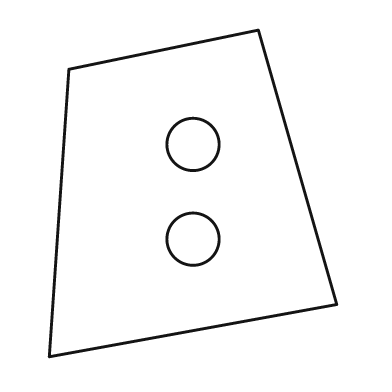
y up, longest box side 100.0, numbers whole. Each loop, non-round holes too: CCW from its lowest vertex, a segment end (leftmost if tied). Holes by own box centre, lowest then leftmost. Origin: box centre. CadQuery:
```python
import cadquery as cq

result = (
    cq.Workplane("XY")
    .moveTo(-44.0, -50.0)
    .lineTo(44.0, -34.0)
    .lineTo(20.0, 50.0)
    .lineTo(-38.0, 38.0)
    .close()
    .moveTo(0.0, -14.0)
    .circle(8.0)
    .moveTo(0.0, 15.0)
    .circle(8.0)
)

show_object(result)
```